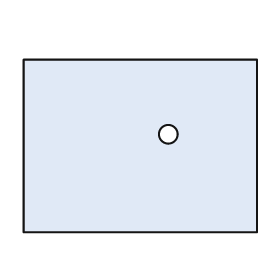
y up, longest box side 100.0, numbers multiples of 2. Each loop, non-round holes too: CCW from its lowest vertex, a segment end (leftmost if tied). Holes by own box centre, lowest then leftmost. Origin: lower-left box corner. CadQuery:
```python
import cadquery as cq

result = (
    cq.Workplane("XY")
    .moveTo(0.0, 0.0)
    .lineTo(100.0, 0.0)
    .lineTo(100.0, 74.0)
    .lineTo(0.0, 74.0)
    .close()
    .moveTo(62.0, 42.0)
    .circle(4.0)
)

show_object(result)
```